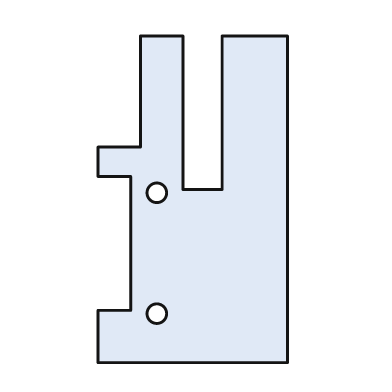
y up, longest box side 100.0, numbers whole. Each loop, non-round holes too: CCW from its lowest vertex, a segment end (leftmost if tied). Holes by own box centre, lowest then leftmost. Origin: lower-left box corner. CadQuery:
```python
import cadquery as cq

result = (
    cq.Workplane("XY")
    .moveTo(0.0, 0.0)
    .lineTo(58.0, 0.0)
    .lineTo(58.0, 100.0)
    .lineTo(38.0, 100.0)
    .lineTo(38.0, 53.0)
    .lineTo(26.0, 53.0)
    .lineTo(26.0, 100.0)
    .lineTo(13.0, 100.0)
    .lineTo(13.0, 66.0)
    .lineTo(0.0, 66.0)
    .lineTo(0.0, 57.0)
    .lineTo(10.0, 57.0)
    .lineTo(10.0, 16.0)
    .lineTo(0.0, 16.0)
    .close()
    .moveTo(18.0, 15.0)
    .circle(3.0)
    .moveTo(18.0, 52.0)
    .circle(3.0)
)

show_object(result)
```